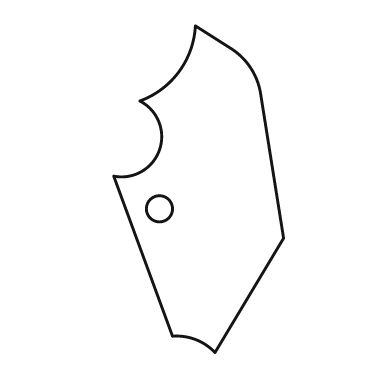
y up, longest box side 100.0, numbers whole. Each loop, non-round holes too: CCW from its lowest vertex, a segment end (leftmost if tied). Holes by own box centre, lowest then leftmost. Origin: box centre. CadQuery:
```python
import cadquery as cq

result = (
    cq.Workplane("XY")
    .moveTo(5.0, -50.0)
    .lineTo(26.0, -15.0)
    .lineTo(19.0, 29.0)
    .threePointArc((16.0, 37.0), (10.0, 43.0))
    .lineTo(-1.0, 50.0)
    .threePointArc((-6.0, 36.0), (-18.0, 27.0))
    .threePointArc((-12.0, 12.0), (-26.0, 4.0))
    .lineTo(-8.0, -45.0)
    .threePointArc((-1.0, -46.0), (5.0, -50.0))
    .close()
    .moveTo(-12.0, -6.0)
    .circle(4.0)
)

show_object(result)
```